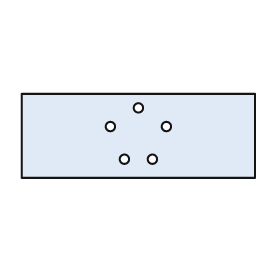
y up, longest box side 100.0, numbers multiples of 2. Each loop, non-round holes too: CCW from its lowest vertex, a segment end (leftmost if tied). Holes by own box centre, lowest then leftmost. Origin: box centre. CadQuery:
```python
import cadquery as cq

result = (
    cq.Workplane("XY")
    .moveTo(-50.0, -18.0)
    .lineTo(50.0, -18.0)
    .lineTo(50.0, 18.0)
    .lineTo(-50.0, 18.0)
    .close()
    .moveTo(-6.0, -10.0)
    .circle(2.0)
    .moveTo(6.0, -10.0)
    .circle(2.0)
    .moveTo(-12.0, 4.0)
    .circle(2.0)
    .moveTo(12.0, 4.0)
    .circle(2.0)
    .moveTo(0.0, 12.0)
    .circle(2.0)
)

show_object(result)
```